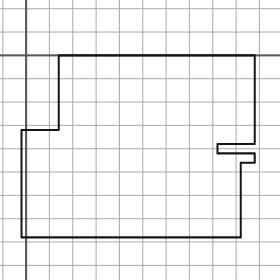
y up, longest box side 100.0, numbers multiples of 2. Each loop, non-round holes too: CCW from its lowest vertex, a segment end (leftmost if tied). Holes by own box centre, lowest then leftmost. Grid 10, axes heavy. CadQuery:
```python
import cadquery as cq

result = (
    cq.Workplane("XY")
    .moveTo(-2.0, -78.0)
    .lineTo(92.0, -78.0)
    .lineTo(92.0, -46.0)
    .lineTo(98.0, -46.0)
    .lineTo(98.0, -42.0)
    .lineTo(82.0, -42.0)
    .lineTo(82.0, -38.0)
    .lineTo(98.0, -38.0)
    .lineTo(98.0, 0.0)
    .lineTo(14.0, 0.0)
    .lineTo(14.0, -32.0)
    .lineTo(-2.0, -32.0)
    .close()
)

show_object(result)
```